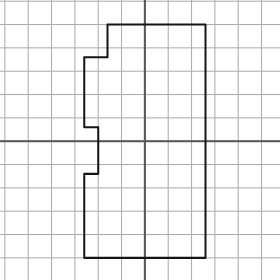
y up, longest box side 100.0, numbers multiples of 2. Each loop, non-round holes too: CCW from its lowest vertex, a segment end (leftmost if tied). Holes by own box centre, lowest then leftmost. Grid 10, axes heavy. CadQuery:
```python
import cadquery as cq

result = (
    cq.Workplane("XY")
    .moveTo(-26.0, -50.0)
    .lineTo(26.0, -50.0)
    .lineTo(26.0, 50.0)
    .lineTo(-16.0, 50.0)
    .lineTo(-16.0, 36.0)
    .lineTo(-26.0, 36.0)
    .lineTo(-26.0, 6.0)
    .lineTo(-20.0, 6.0)
    .lineTo(-20.0, -14.0)
    .lineTo(-26.0, -14.0)
    .close()
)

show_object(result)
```